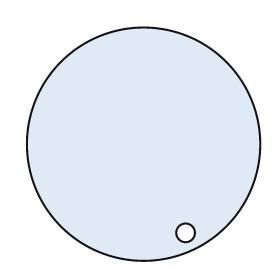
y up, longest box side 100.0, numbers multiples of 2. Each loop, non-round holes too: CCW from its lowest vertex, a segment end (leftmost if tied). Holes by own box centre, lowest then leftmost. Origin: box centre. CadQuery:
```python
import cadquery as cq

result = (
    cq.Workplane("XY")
    .moveTo(0.0, 0.0)
    .circle(50.0)
    .moveTo(18.0, -38.0)
    .circle(4.0)
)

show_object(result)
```